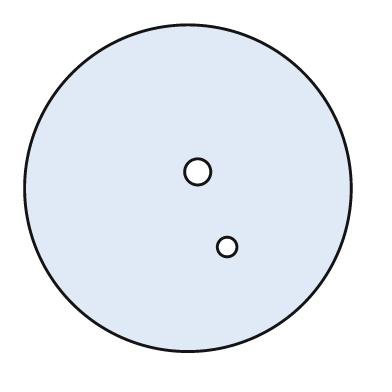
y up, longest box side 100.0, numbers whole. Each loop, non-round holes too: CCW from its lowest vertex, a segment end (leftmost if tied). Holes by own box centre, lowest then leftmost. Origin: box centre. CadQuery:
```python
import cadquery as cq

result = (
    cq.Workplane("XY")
    .moveTo(0.0, 0.0)
    .circle(50.0)
    .moveTo(12.0, -18.0)
    .circle(3.0)
    .moveTo(3.0, 5.0)
    .circle(4.0)
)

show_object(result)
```